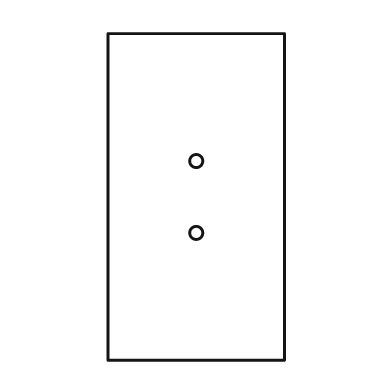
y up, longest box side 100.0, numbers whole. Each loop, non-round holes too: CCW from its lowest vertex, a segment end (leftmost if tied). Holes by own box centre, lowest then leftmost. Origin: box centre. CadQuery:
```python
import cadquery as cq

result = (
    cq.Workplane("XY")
    .moveTo(-27.0, -50.0)
    .lineTo(27.0, -50.0)
    .lineTo(27.0, 50.0)
    .lineTo(-27.0, 50.0)
    .close()
    .moveTo(0.0, -11.0)
    .circle(2.0)
    .moveTo(0.0, 11.0)
    .circle(2.0)
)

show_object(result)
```